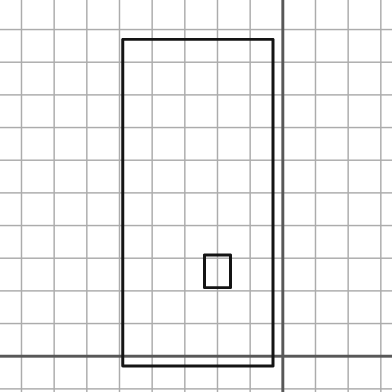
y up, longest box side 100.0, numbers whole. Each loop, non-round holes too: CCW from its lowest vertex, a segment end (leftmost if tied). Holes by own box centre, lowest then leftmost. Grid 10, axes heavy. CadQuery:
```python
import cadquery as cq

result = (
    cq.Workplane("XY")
    .moveTo(-49.0, -3.0)
    .lineTo(-3.0, -3.0)
    .lineTo(-3.0, 97.0)
    .lineTo(-49.0, 97.0)
    .close()
    .moveTo(-24.0, 21.0)
    .lineTo(-16.0, 21.0)
    .lineTo(-16.0, 31.0)
    .lineTo(-24.0, 31.0)
    .close()
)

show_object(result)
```